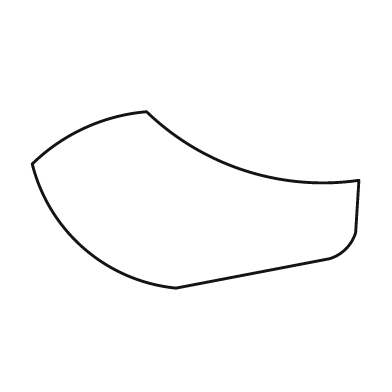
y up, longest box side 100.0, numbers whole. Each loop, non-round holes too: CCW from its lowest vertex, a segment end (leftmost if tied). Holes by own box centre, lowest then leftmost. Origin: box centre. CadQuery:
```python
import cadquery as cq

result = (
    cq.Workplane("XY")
    .moveTo(-6.0, -27.0)
    .lineTo(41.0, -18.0)
    .threePointArc((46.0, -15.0), (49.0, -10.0))
    .lineTo(50.0, 6.0)
    .threePointArc((15.0, 9.0), (-15.0, 27.0))
    .threePointArc((-34.0, 22.0), (-50.0, 11.0))
    .threePointArc((-34.0, -15.0), (-6.0, -27.0))
    .close()
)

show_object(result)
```